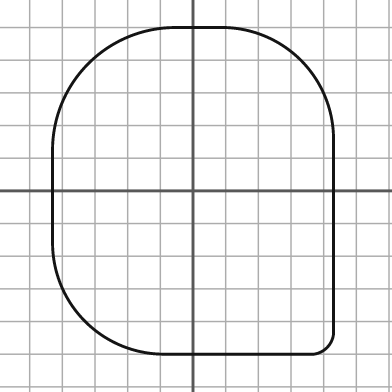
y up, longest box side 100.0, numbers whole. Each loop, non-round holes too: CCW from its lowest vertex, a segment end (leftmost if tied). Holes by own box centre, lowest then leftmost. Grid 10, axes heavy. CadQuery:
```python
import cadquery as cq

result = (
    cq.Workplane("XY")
    .moveTo(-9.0, -50.0)
    .lineTo(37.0, -50.0)
    .threePointArc((41.0, -48.0), (43.0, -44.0))
    .lineTo(43.0, 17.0)
    .threePointArc((33.0, 40.0), (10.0, 50.0))
    .lineTo(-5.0, 50.0)
    .threePointArc((-32.0, 39.0), (-43.0, 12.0))
    .lineTo(-43.0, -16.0)
    .threePointArc((-33.0, -40.0), (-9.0, -50.0))
    .close()
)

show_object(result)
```